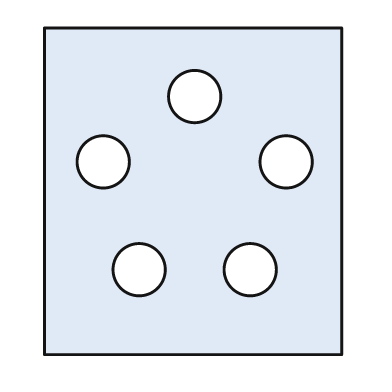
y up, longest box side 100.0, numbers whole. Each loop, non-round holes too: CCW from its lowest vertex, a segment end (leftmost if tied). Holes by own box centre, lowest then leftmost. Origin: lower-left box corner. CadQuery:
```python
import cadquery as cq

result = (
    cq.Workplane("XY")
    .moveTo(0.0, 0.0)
    .lineTo(91.0, 0.0)
    .lineTo(91.0, 100.0)
    .lineTo(0.0, 100.0)
    .close()
    .moveTo(29.0, 26.0)
    .circle(8.0)
    .moveTo(63.0, 26.0)
    .circle(8.0)
    .moveTo(18.0, 59.0)
    .circle(8.0)
    .moveTo(74.0, 59.0)
    .circle(8.0)
    .moveTo(46.0, 79.0)
    .circle(8.0)
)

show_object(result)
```